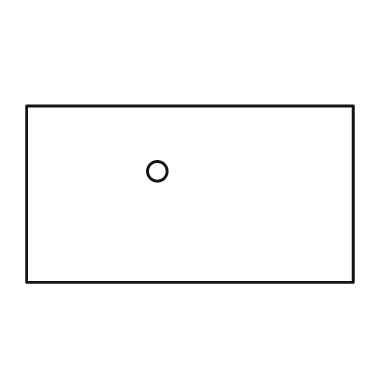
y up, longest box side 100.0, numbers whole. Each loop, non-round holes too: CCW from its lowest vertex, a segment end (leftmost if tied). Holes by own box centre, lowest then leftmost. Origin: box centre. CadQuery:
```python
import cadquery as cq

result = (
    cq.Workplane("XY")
    .moveTo(-50.0, -27.0)
    .lineTo(50.0, -27.0)
    .lineTo(50.0, 27.0)
    .lineTo(-50.0, 27.0)
    .close()
    .moveTo(-10.0, 7.0)
    .circle(3.0)
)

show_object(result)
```